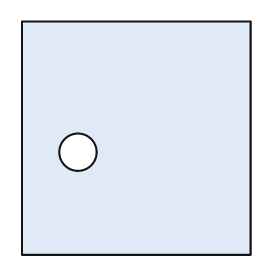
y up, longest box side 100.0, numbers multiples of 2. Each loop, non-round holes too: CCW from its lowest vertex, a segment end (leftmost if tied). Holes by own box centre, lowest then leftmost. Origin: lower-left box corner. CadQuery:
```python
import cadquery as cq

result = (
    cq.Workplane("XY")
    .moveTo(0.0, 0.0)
    .lineTo(98.0, 0.0)
    .lineTo(98.0, 100.0)
    .lineTo(0.0, 100.0)
    .close()
    .moveTo(24.0, 44.0)
    .circle(8.0)
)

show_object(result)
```